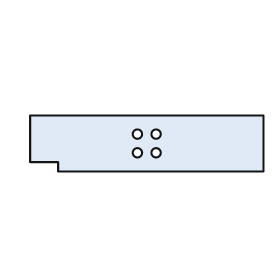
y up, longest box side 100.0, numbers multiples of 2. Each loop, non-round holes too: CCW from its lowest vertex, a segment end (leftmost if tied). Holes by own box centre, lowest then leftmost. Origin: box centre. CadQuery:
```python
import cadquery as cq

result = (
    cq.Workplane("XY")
    .moveTo(-38.0, -12.0)
    .lineTo(50.0, -12.0)
    .lineTo(50.0, 12.0)
    .lineTo(-50.0, 12.0)
    .lineTo(-50.0, -8.0)
    .lineTo(-38.0, -8.0)
    .close()
    .moveTo(-4.0, -4.0)
    .circle(2.0)
    .moveTo(4.0, -4.0)
    .circle(2.0)
    .moveTo(-4.0, 4.0)
    .circle(2.0)
    .moveTo(4.0, 4.0)
    .circle(2.0)
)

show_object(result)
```